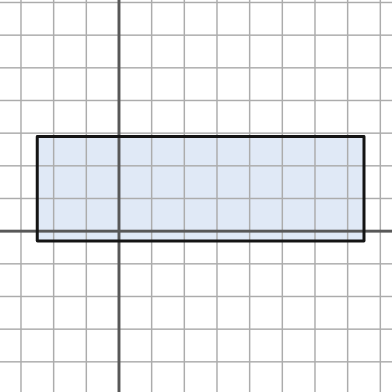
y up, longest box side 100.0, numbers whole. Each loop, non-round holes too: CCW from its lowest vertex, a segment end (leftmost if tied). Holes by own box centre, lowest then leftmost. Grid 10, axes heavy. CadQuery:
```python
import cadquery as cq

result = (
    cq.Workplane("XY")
    .moveTo(-25.0, -3.0)
    .lineTo(75.0, -3.0)
    .lineTo(75.0, 29.0)
    .lineTo(-25.0, 29.0)
    .close()
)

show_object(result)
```